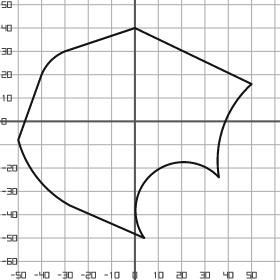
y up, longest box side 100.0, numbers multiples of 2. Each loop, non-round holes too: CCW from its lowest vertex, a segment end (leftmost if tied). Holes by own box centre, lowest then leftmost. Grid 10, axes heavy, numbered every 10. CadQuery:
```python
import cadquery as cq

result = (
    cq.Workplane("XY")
    .moveTo(4.0, -50.0)
    .threePointArc((8.0, -22.0), (36.0, -24.0))
    .threePointArc((38.0, -2.0), (50.0, 16.0))
    .lineTo(0.0, 40.0)
    .lineTo(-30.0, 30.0)
    .threePointArc((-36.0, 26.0), (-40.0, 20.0))
    .lineTo(-50.0, -8.0)
    .threePointArc((-42.0, -24.0), (-28.0, -36.0))
    .close()
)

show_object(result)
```